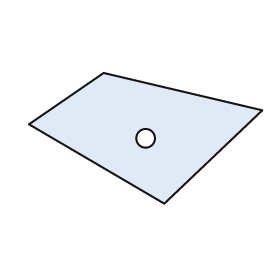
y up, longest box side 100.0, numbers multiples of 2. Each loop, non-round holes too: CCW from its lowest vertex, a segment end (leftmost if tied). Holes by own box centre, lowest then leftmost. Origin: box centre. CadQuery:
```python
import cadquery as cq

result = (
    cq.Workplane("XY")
    .moveTo(8.0, -28.0)
    .lineTo(50.0, 12.0)
    .lineTo(-18.0, 28.0)
    .lineTo(-50.0, 6.0)
    .close()
    .moveTo(0.0, 0.0)
    .circle(4.0)
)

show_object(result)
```